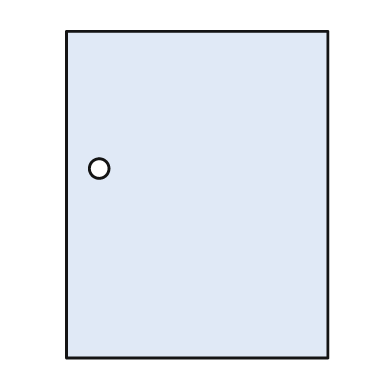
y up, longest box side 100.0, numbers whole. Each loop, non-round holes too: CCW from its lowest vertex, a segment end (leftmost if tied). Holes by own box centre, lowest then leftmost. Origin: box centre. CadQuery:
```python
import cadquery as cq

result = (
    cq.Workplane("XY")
    .moveTo(-40.0, -50.0)
    .lineTo(40.0, -50.0)
    .lineTo(40.0, 50.0)
    .lineTo(-40.0, 50.0)
    .close()
    .moveTo(-30.0, 8.0)
    .circle(3.0)
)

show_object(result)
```